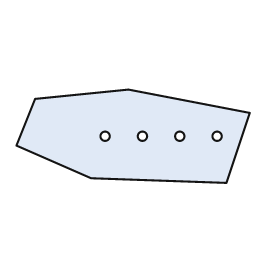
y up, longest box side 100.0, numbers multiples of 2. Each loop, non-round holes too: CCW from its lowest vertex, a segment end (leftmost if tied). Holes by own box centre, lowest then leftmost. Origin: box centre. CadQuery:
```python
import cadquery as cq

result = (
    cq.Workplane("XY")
    .moveTo(40.0, -20.0)
    .lineTo(50.0, 10.0)
    .lineTo(-2.0, 20.0)
    .lineTo(-42.0, 16.0)
    .lineTo(-50.0, -4.0)
    .lineTo(-18.0, -18.0)
    .close()
    .moveTo(-12.0, 0.0)
    .circle(2.0)
    .moveTo(4.0, 0.0)
    .circle(2.0)
    .moveTo(20.0, 0.0)
    .circle(2.0)
    .moveTo(36.0, 0.0)
    .circle(2.0)
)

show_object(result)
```